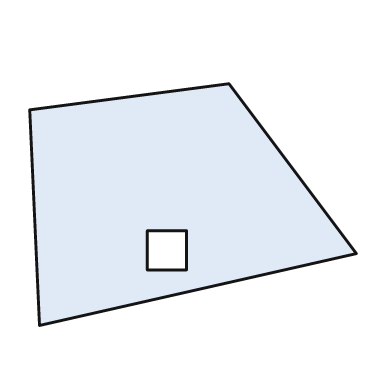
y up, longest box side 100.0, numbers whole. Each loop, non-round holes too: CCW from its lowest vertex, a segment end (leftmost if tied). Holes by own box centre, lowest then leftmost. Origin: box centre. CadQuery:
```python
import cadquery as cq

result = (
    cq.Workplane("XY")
    .moveTo(-47.0, -37.0)
    .lineTo(50.0, -15.0)
    .lineTo(11.0, 37.0)
    .lineTo(-50.0, 29.0)
    .close()
    .moveTo(-14.0, -20.0)
    .lineTo(-2.0, -20.0)
    .lineTo(-2.0, -8.0)
    .lineTo(-14.0, -8.0)
    .close()
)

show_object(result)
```